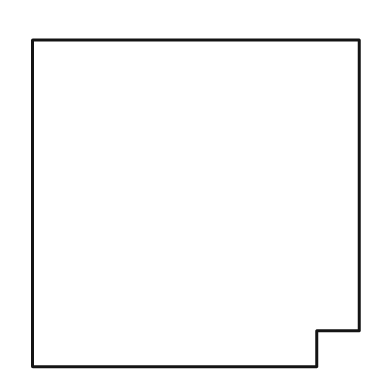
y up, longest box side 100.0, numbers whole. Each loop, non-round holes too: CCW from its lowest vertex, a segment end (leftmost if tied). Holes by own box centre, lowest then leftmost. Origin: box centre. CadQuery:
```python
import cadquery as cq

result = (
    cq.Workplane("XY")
    .moveTo(-50.0, -50.0)
    .lineTo(37.0, -50.0)
    .lineTo(37.0, -39.0)
    .lineTo(50.0, -39.0)
    .lineTo(50.0, 50.0)
    .lineTo(-50.0, 50.0)
    .close()
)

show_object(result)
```